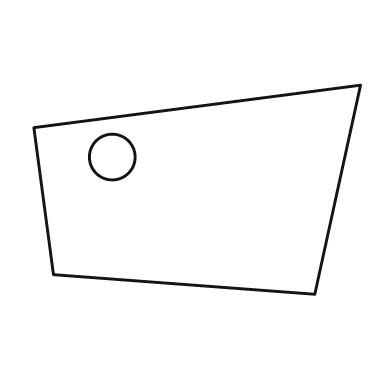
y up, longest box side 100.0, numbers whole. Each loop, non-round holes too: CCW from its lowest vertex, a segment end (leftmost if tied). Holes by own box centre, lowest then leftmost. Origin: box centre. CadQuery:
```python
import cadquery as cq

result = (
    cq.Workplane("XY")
    .moveTo(36.0, -32.0)
    .lineTo(50.0, 32.0)
    .lineTo(-50.0, 19.0)
    .lineTo(-44.0, -26.0)
    .close()
    .moveTo(-26.0, 10.0)
    .circle(7.0)
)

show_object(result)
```